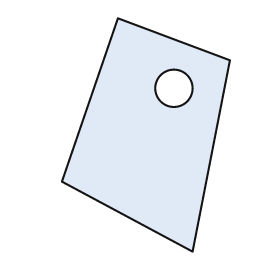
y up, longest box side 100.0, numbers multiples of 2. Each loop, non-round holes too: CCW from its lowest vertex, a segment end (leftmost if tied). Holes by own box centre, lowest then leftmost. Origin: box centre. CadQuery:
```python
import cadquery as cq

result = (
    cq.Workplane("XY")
    .moveTo(20.0, -50.0)
    .lineTo(36.0, 32.0)
    .lineTo(-12.0, 50.0)
    .lineTo(-36.0, -20.0)
    .close()
    .moveTo(12.0, 20.0)
    .circle(8.0)
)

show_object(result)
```